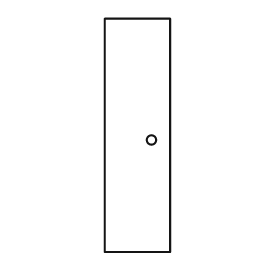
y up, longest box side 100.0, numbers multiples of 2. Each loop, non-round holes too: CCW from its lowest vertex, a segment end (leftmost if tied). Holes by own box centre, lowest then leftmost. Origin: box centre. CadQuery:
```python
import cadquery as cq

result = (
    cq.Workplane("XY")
    .moveTo(-14.0, -50.0)
    .lineTo(14.0, -50.0)
    .lineTo(14.0, 50.0)
    .lineTo(-14.0, 50.0)
    .close()
    .moveTo(6.0, -2.0)
    .circle(2.0)
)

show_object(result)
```